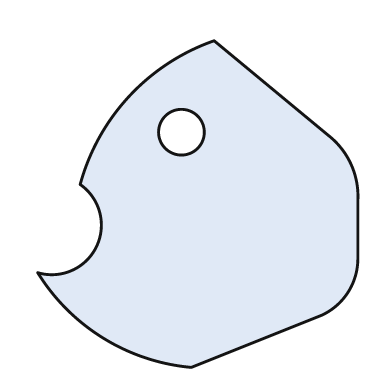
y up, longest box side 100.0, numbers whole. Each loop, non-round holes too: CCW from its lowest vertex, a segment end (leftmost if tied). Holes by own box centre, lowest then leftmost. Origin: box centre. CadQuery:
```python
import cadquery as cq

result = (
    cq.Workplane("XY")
    .moveTo(-2.0, -50.0)
    .lineTo(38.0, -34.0)
    .threePointArc((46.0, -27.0), (49.0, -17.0))
    .lineTo(49.0, 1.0)
    .threePointArc((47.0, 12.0), (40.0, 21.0))
    .lineTo(5.0, 50.0)
    .threePointArc((-21.0, 33.0), (-36.0, 6.0))
    .threePointArc((-31.0, -13.0), (-49.0, -21.0))
    .threePointArc((-29.0, -41.0), (-2.0, -50.0))
    .close()
    .moveTo(-5.0, 22.0)
    .circle(7.0)
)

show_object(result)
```